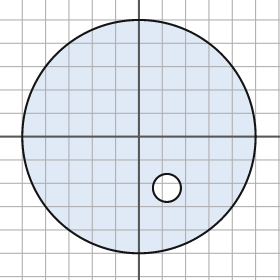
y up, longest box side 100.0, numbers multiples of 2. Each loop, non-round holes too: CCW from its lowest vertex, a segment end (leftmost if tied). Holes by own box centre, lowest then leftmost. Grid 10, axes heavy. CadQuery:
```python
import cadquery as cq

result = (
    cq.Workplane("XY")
    .moveTo(0.0, 0.0)
    .circle(50.0)
    .moveTo(12.0, -22.0)
    .circle(6.0)
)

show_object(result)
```